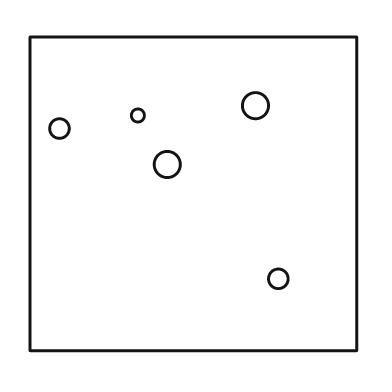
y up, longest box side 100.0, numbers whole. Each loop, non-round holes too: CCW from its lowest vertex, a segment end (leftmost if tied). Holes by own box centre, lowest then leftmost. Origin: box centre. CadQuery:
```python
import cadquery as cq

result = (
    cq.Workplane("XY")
    .moveTo(-50.0, -48.0)
    .lineTo(50.0, -48.0)
    .lineTo(50.0, 48.0)
    .lineTo(-50.0, 48.0)
    .close()
    .moveTo(26.0, -26.0)
    .circle(3.0)
    .moveTo(-8.0, 9.0)
    .circle(4.0)
    .moveTo(-41.0, 20.0)
    .circle(3.0)
    .moveTo(-17.0, 24.0)
    .circle(2.0)
    .moveTo(19.0, 27.0)
    .circle(4.0)
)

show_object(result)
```